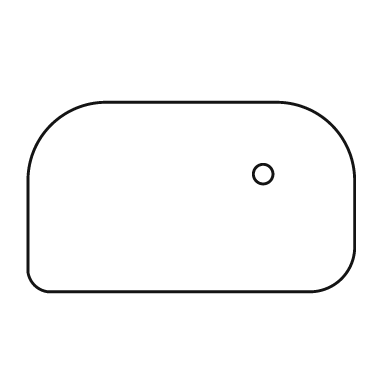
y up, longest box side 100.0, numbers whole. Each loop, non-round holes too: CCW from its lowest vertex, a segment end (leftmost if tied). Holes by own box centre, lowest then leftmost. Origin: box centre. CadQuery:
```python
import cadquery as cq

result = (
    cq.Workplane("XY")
    .moveTo(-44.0, -29.0)
    .lineTo(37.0, -29.0)
    .threePointArc((46.0, -25.0), (50.0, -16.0))
    .lineTo(50.0, 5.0)
    .threePointArc((43.0, 22.0), (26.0, 29.0))
    .lineTo(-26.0, 29.0)
    .threePointArc((-43.0, 22.0), (-50.0, 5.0))
    .lineTo(-50.0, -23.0)
    .threePointArc((-48.0, -27.0), (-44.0, -29.0))
    .close()
    .moveTo(22.0, 7.0)
    .circle(3.0)
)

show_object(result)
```